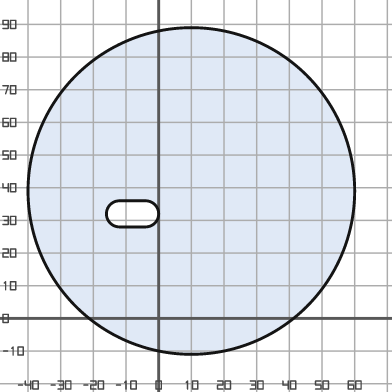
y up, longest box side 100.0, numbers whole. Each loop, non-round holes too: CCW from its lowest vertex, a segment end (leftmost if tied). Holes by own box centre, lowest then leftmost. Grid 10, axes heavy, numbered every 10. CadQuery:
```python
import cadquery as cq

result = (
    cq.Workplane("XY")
    .moveTo(10.0, 39.0)
    .circle(50.0)
    .moveTo(-12.0, 28.0)
    .lineTo(-4.0, 28.0)
    .threePointArc((0.0, 32.0), (-4.0, 36.0))
    .lineTo(-12.0, 36.0)
    .threePointArc((-16.0, 32.0), (-12.0, 28.0))
    .close()
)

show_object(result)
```